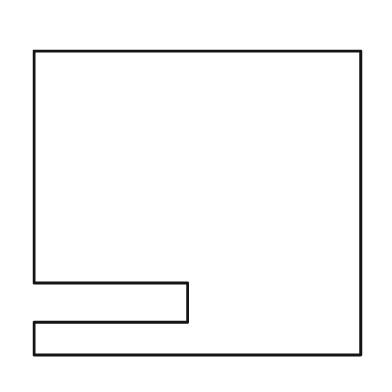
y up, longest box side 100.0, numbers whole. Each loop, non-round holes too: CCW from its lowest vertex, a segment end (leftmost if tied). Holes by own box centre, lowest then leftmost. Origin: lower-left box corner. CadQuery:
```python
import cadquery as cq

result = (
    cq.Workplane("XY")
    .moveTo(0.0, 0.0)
    .lineTo(100.0, 0.0)
    .lineTo(100.0, 93.0)
    .lineTo(0.0, 93.0)
    .lineTo(0.0, 22.0)
    .lineTo(47.0, 22.0)
    .lineTo(47.0, 10.0)
    .lineTo(0.0, 10.0)
    .close()
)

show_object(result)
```